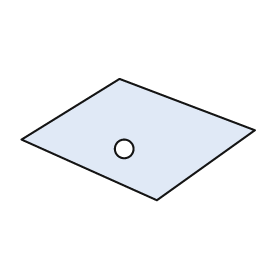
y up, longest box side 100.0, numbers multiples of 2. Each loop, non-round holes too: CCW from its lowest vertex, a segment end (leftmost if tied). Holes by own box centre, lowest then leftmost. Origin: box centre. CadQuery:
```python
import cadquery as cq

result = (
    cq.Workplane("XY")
    .moveTo(8.0, -26.0)
    .lineTo(50.0, 4.0)
    .lineTo(-8.0, 26.0)
    .lineTo(-50.0, 0.0)
    .close()
    .moveTo(-6.0, -4.0)
    .circle(4.0)
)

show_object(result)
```